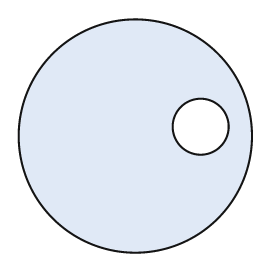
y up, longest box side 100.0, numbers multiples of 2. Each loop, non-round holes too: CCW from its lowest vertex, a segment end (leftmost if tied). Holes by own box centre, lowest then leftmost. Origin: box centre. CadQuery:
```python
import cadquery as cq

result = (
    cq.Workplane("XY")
    .moveTo(0.0, 0.0)
    .circle(50.0)
    .moveTo(28.0, 4.0)
    .circle(12.0)
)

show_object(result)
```